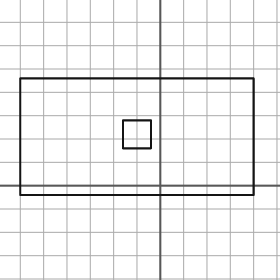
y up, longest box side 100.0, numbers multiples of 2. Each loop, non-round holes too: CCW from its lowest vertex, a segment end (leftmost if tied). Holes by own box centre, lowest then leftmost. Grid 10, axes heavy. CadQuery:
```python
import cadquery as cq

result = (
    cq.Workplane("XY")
    .moveTo(-60.0, -4.0)
    .lineTo(40.0, -4.0)
    .lineTo(40.0, 46.0)
    .lineTo(-60.0, 46.0)
    .close()
    .moveTo(-16.0, 16.0)
    .lineTo(-4.0, 16.0)
    .lineTo(-4.0, 28.0)
    .lineTo(-16.0, 28.0)
    .close()
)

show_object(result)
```